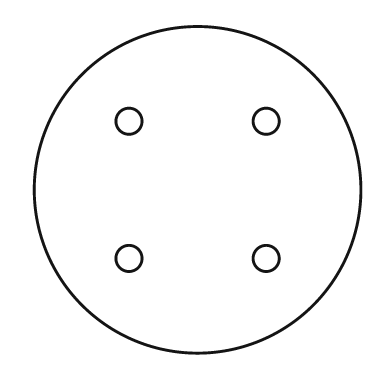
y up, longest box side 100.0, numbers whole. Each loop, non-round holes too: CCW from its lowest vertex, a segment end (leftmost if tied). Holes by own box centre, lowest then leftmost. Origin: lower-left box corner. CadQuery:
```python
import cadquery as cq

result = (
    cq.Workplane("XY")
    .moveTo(50.0, 50.0)
    .circle(50.0)
    .moveTo(29.0, 29.0)
    .circle(4.0)
    .moveTo(71.0, 29.0)
    .circle(4.0)
    .moveTo(29.0, 71.0)
    .circle(4.0)
    .moveTo(71.0, 71.0)
    .circle(4.0)
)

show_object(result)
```